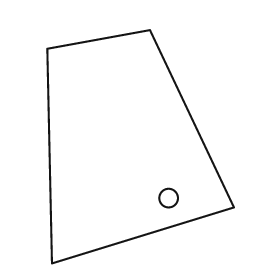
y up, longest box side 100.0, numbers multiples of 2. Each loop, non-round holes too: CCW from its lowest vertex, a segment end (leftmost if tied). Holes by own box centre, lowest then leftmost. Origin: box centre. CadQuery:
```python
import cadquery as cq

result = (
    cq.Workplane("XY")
    .moveTo(-38.0, -50.0)
    .lineTo(40.0, -26.0)
    .lineTo(4.0, 50.0)
    .lineTo(-40.0, 42.0)
    .close()
    .moveTo(12.0, -22.0)
    .circle(4.0)
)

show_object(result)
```